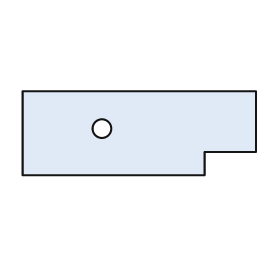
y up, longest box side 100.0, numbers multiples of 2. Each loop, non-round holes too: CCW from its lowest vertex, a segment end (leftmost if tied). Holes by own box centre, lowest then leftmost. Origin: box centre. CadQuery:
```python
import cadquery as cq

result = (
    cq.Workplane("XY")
    .moveTo(-50.0, -18.0)
    .lineTo(28.0, -18.0)
    .lineTo(28.0, -8.0)
    .lineTo(50.0, -8.0)
    .lineTo(50.0, 18.0)
    .lineTo(-50.0, 18.0)
    .close()
    .moveTo(-16.0, 2.0)
    .circle(4.0)
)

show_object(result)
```